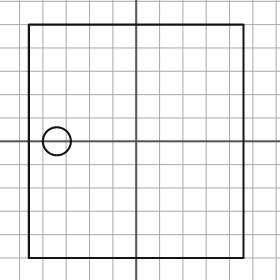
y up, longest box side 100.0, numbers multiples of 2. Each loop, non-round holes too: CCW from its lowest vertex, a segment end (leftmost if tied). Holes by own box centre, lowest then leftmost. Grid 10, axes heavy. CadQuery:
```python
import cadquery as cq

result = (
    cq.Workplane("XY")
    .moveTo(-46.0, -50.0)
    .lineTo(46.0, -50.0)
    .lineTo(46.0, 50.0)
    .lineTo(-46.0, 50.0)
    .close()
    .moveTo(-34.0, 0.0)
    .circle(6.0)
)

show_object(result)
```